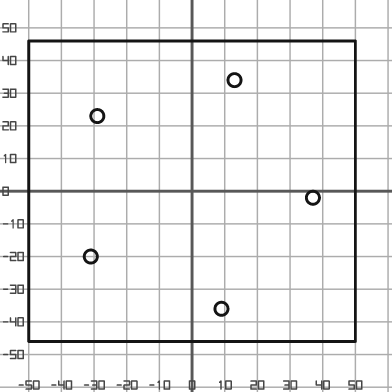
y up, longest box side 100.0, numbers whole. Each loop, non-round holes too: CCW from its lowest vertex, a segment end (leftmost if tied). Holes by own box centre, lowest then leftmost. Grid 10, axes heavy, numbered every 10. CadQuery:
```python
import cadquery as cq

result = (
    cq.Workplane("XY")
    .moveTo(-50.0, -46.0)
    .lineTo(50.0, -46.0)
    .lineTo(50.0, 46.0)
    .lineTo(-50.0, 46.0)
    .close()
    .moveTo(9.0, -36.0)
    .circle(2.0)
    .moveTo(-31.0, -20.0)
    .circle(2.0)
    .moveTo(37.0, -2.0)
    .circle(2.0)
    .moveTo(-29.0, 23.0)
    .circle(2.0)
    .moveTo(13.0, 34.0)
    .circle(2.0)
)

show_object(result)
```